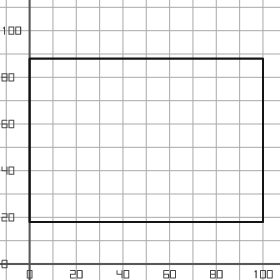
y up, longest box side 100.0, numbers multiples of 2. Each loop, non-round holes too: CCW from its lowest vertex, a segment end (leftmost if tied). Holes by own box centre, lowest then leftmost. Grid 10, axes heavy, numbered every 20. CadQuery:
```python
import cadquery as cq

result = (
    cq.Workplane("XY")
    .moveTo(0.0, 18.0)
    .lineTo(100.0, 18.0)
    .lineTo(100.0, 88.0)
    .lineTo(0.0, 88.0)
    .close()
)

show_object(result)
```